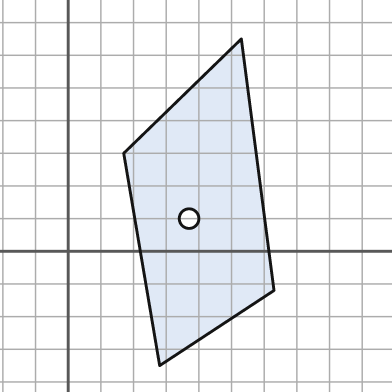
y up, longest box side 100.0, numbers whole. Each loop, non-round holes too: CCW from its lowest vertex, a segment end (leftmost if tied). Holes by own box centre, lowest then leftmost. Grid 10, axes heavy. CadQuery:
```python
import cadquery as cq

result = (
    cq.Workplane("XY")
    .moveTo(28.0, -35.0)
    .lineTo(63.0, -12.0)
    .lineTo(53.0, 65.0)
    .lineTo(17.0, 30.0)
    .close()
    .moveTo(37.0, 10.0)
    .circle(3.0)
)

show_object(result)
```